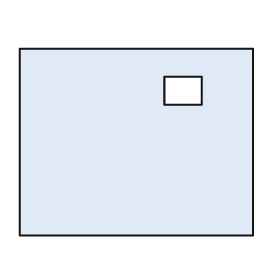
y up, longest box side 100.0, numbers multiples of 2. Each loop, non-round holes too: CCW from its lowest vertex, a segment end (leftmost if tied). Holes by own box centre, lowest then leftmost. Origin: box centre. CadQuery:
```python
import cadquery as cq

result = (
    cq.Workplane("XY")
    .moveTo(-50.0, -40.0)
    .lineTo(50.0, -40.0)
    .lineTo(50.0, 40.0)
    .lineTo(-50.0, 40.0)
    .close()
    .moveTo(12.0, 16.0)
    .lineTo(28.0, 16.0)
    .lineTo(28.0, 28.0)
    .lineTo(12.0, 28.0)
    .close()
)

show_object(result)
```